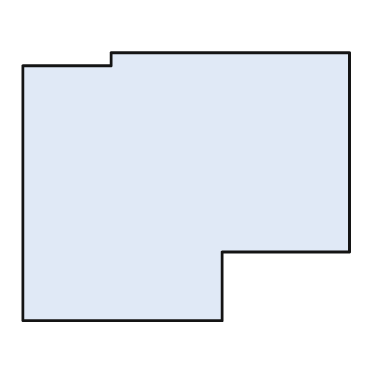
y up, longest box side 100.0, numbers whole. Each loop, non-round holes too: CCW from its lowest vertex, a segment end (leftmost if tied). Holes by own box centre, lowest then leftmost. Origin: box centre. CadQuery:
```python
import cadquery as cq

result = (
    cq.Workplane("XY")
    .moveTo(-50.0, -41.0)
    .lineTo(11.0, -41.0)
    .lineTo(11.0, -20.0)
    .lineTo(50.0, -20.0)
    .lineTo(50.0, 41.0)
    .lineTo(-23.0, 41.0)
    .lineTo(-23.0, 37.0)
    .lineTo(-50.0, 37.0)
    .close()
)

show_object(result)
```